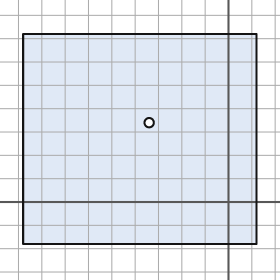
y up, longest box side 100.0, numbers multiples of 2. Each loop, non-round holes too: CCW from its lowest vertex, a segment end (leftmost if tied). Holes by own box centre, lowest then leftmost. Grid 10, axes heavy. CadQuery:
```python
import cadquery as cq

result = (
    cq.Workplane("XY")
    .moveTo(-88.0, -18.0)
    .lineTo(12.0, -18.0)
    .lineTo(12.0, 72.0)
    .lineTo(-88.0, 72.0)
    .close()
    .moveTo(-34.0, 34.0)
    .circle(2.0)
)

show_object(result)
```